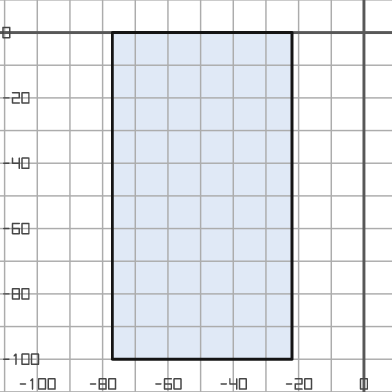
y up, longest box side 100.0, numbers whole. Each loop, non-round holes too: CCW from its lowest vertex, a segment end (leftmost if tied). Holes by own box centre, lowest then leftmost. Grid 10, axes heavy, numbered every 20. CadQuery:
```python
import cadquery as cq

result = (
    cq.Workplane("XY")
    .moveTo(-77.0, -100.0)
    .lineTo(-22.0, -100.0)
    .lineTo(-22.0, 0.0)
    .lineTo(-77.0, 0.0)
    .close()
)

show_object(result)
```